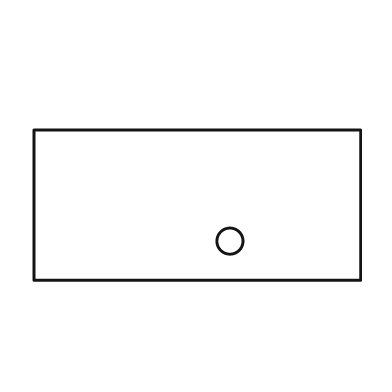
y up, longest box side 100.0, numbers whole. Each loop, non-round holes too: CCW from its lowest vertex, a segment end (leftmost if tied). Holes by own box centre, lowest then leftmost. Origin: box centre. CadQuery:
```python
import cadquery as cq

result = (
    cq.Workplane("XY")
    .moveTo(-50.0, -23.0)
    .lineTo(50.0, -23.0)
    .lineTo(50.0, 23.0)
    .lineTo(-50.0, 23.0)
    .close()
    .moveTo(10.0, -11.0)
    .circle(4.0)
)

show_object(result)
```